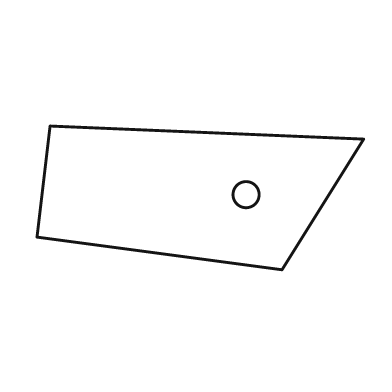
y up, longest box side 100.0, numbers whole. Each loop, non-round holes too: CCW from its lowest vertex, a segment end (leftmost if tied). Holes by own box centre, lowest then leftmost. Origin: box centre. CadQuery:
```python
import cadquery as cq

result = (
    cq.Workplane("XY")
    .moveTo(25.0, -22.0)
    .lineTo(50.0, 18.0)
    .lineTo(-46.0, 22.0)
    .lineTo(-50.0, -12.0)
    .close()
    .moveTo(14.0, 1.0)
    .circle(4.0)
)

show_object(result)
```